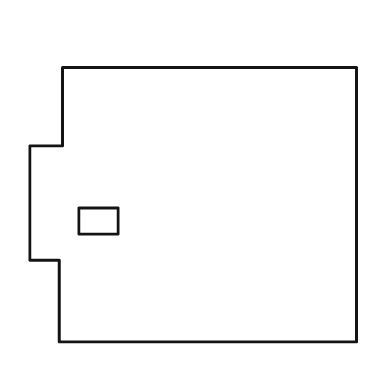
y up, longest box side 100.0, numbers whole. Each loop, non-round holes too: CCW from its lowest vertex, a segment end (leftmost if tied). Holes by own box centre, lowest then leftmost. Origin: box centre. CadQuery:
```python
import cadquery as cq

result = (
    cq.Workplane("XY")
    .moveTo(-41.0, -42.0)
    .lineTo(50.0, -42.0)
    .lineTo(50.0, 42.0)
    .lineTo(-40.0, 42.0)
    .lineTo(-40.0, 18.0)
    .lineTo(-50.0, 18.0)
    .lineTo(-50.0, -17.0)
    .lineTo(-41.0, -17.0)
    .close()
    .moveTo(-35.0, -9.0)
    .lineTo(-23.0, -9.0)
    .lineTo(-23.0, -1.0)
    .lineTo(-35.0, -1.0)
    .close()
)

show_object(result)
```